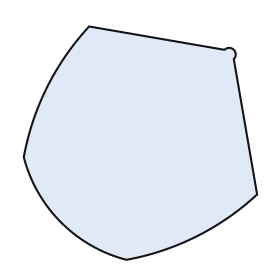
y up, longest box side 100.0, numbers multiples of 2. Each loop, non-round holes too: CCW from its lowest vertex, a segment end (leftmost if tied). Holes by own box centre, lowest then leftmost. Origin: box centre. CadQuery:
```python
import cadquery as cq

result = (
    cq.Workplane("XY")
    .moveTo(-6.0, -50.0)
    .threePointArc((24.0, -40.0), (50.0, -22.0))
    .lineTo(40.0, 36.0)
    .threePointArc((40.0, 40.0), (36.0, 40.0))
    .lineTo(-22.0, 50.0)
    .threePointArc((-40.0, 24.0), (-50.0, -6.0))
    .threePointArc((-34.0, -34.0), (-6.0, -50.0))
    .close()
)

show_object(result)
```